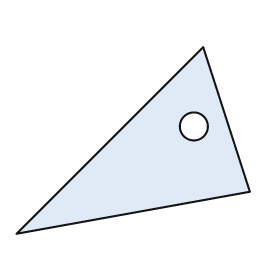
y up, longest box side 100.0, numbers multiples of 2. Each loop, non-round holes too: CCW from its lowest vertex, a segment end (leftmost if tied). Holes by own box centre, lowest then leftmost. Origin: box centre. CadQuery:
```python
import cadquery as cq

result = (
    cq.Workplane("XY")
    .moveTo(-50.0, -40.0)
    .lineTo(50.0, -22.0)
    .lineTo(30.0, 40.0)
    .close()
    .moveTo(26.0, 6.0)
    .circle(6.0)
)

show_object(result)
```